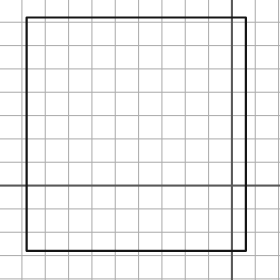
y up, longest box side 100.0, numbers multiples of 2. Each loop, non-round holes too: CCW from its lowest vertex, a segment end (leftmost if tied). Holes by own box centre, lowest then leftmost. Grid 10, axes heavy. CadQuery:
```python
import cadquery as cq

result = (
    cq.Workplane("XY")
    .moveTo(-88.0, -28.0)
    .lineTo(6.0, -28.0)
    .lineTo(6.0, 72.0)
    .lineTo(-88.0, 72.0)
    .close()
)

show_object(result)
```